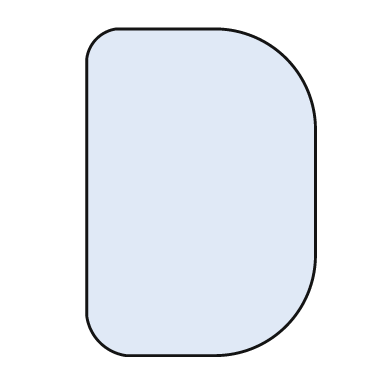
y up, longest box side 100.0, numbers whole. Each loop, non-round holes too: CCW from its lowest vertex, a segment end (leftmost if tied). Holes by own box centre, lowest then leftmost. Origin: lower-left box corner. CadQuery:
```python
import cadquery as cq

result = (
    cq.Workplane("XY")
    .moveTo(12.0, 0.0)
    .lineTo(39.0, 0.0)
    .threePointArc((61.0, 9.0), (70.0, 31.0))
    .lineTo(70.0, 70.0)
    .threePointArc((61.0, 91.0), (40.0, 100.0))
    .lineTo(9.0, 100.0)
    .threePointArc((3.0, 97.0), (0.0, 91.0))
    .lineTo(0.0, 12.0)
    .threePointArc((4.0, 4.0), (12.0, 0.0))
    .close()
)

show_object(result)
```